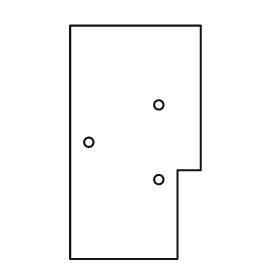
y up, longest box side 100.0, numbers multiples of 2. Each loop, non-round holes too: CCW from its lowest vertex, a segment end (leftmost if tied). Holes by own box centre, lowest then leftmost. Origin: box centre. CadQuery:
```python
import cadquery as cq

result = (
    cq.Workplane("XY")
    .moveTo(-28.0, -50.0)
    .lineTo(18.0, -50.0)
    .lineTo(18.0, -12.0)
    .lineTo(28.0, -12.0)
    .lineTo(28.0, 50.0)
    .lineTo(-28.0, 50.0)
    .close()
    .moveTo(10.0, -16.0)
    .circle(2.0)
    .moveTo(-20.0, 0.0)
    .circle(2.0)
    .moveTo(10.0, 16.0)
    .circle(2.0)
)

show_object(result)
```